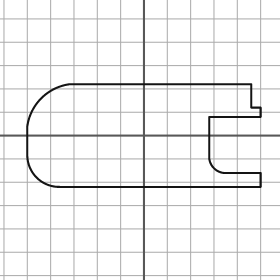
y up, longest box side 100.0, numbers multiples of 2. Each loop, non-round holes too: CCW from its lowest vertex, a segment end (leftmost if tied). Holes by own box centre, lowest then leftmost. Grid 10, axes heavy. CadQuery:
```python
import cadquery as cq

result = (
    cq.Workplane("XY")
    .moveTo(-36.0, -22.0)
    .lineTo(50.0, -22.0)
    .lineTo(50.0, -16.0)
    .lineTo(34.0, -16.0)
    .threePointArc((30.0, -14.0), (28.0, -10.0))
    .lineTo(28.0, 8.0)
    .lineTo(50.0, 8.0)
    .lineTo(50.0, 12.0)
    .lineTo(46.0, 12.0)
    .lineTo(46.0, 22.0)
    .lineTo(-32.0, 22.0)
    .threePointArc((-44.0, 16.0), (-50.0, 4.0))
    .lineTo(-50.0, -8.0)
    .threePointArc((-46.0, -18.0), (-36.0, -22.0))
    .close()
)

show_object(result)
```